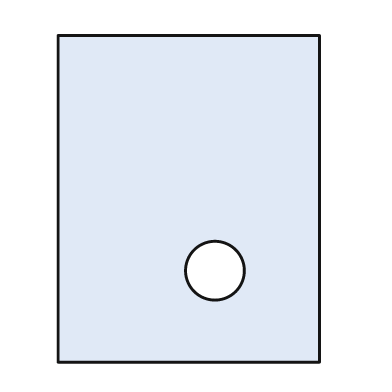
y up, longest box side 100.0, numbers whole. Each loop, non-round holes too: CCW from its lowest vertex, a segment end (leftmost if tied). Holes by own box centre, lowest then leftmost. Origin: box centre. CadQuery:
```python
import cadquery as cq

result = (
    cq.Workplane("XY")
    .moveTo(-40.0, -50.0)
    .lineTo(40.0, -50.0)
    .lineTo(40.0, 50.0)
    .lineTo(-40.0, 50.0)
    .close()
    .moveTo(8.0, -22.0)
    .circle(9.0)
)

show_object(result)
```